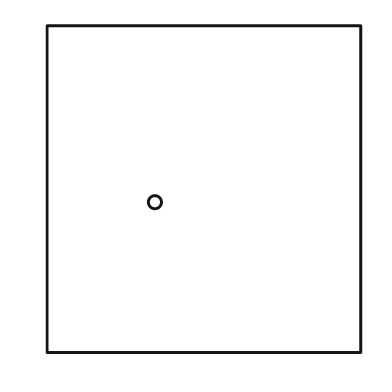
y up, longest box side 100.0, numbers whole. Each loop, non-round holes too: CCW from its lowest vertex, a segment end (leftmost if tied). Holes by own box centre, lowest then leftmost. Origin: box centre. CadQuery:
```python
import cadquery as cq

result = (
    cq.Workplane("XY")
    .moveTo(-48.0, -50.0)
    .lineTo(48.0, -50.0)
    .lineTo(48.0, 50.0)
    .lineTo(-48.0, 50.0)
    .close()
    .moveTo(-15.0, -4.0)
    .circle(2.0)
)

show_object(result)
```